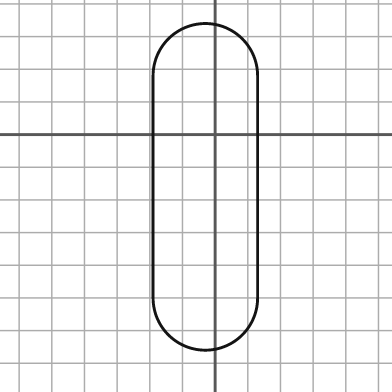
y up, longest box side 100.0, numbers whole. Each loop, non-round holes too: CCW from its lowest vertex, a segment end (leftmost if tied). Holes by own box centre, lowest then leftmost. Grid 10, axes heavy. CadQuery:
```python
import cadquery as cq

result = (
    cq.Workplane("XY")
    .moveTo(-19.0, -50.0)
    .threePointArc((-3.0, -66.0), (13.0, -50.0))
    .lineTo(13.0, 18.0)
    .threePointArc((-3.0, 34.0), (-19.0, 18.0))
    .close()
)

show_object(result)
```